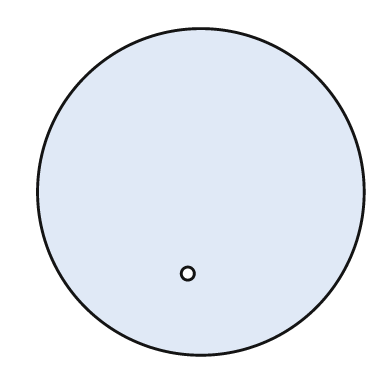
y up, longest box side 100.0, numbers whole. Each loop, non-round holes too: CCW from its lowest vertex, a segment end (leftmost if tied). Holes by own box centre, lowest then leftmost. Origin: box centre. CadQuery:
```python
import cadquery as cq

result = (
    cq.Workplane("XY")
    .moveTo(0.0, 0.0)
    .circle(50.0)
    .moveTo(-4.0, -25.0)
    .circle(2.0)
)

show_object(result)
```